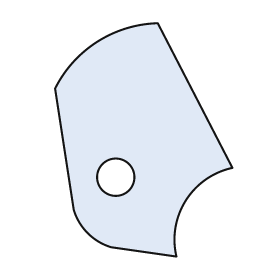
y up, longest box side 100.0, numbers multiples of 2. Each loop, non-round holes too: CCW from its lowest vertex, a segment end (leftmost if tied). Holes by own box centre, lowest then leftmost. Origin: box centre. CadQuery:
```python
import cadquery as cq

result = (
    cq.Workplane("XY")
    .moveTo(14.0, -50.0)
    .threePointArc((18.0, -26.0), (38.0, -12.0))
    .lineTo(6.0, 50.0)
    .threePointArc((-20.0, 42.0), (-38.0, 22.0))
    .lineTo(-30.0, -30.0)
    .threePointArc((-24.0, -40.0), (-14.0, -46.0))
    .close()
    .moveTo(-12.0, -16.0)
    .circle(8.0)
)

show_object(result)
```